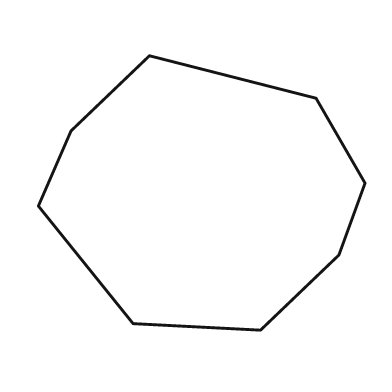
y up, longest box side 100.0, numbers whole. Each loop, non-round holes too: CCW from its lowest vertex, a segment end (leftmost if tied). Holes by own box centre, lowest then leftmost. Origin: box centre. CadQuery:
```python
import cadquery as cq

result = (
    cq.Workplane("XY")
    .moveTo(18.0, -42.0)
    .lineTo(42.0, -19.0)
    .lineTo(50.0, 3.0)
    .lineTo(35.0, 29.0)
    .lineTo(-16.0, 42.0)
    .lineTo(-40.0, 19.0)
    .lineTo(-50.0, -4.0)
    .lineTo(-21.0, -40.0)
    .close()
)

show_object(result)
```